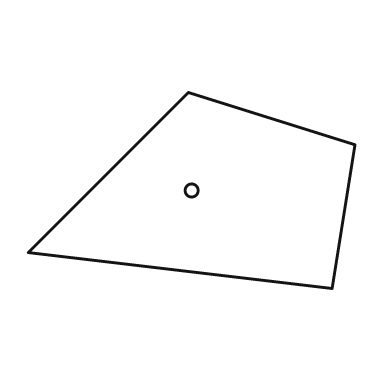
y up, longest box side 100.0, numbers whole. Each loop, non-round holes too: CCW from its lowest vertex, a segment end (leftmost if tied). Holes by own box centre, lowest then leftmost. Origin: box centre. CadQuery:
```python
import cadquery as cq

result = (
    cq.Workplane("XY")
    .moveTo(43.0, -30.0)
    .lineTo(50.0, 14.0)
    .lineTo(-1.0, 30.0)
    .lineTo(-50.0, -19.0)
    .close()
    .moveTo(0.0, 0.0)
    .circle(2.0)
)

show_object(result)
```